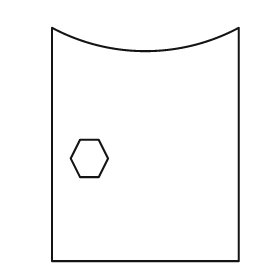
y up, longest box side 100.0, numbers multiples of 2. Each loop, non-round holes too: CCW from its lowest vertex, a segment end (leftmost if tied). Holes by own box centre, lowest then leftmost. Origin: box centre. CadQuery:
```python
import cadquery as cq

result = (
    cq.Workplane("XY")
    .moveTo(-40.0, -50.0)
    .lineTo(40.0, -50.0)
    .lineTo(40.0, 50.0)
    .threePointArc((0.0, 40.0), (-40.0, 50.0))
    .close()
    .moveTo(-28.0, -14.0)
    .lineTo(-20.0, -14.0)
    .lineTo(-16.0, -6.0)
    .lineTo(-20.0, 2.0)
    .lineTo(-28.0, 2.0)
    .lineTo(-32.0, -6.0)
    .close()
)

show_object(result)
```